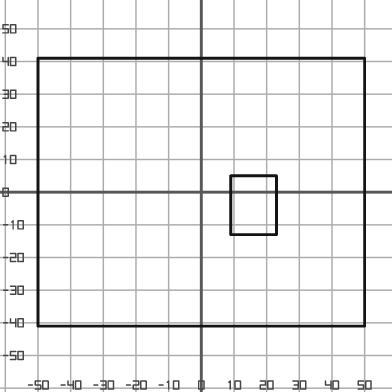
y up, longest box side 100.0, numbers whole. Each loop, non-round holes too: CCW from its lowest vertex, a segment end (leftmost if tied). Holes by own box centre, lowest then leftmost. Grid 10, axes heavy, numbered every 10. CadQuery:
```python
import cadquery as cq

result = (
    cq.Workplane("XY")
    .moveTo(-50.0, -41.0)
    .lineTo(50.0, -41.0)
    .lineTo(50.0, 41.0)
    .lineTo(-50.0, 41.0)
    .close()
    .moveTo(9.0, -13.0)
    .lineTo(23.0, -13.0)
    .lineTo(23.0, 5.0)
    .lineTo(9.0, 5.0)
    .close()
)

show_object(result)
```